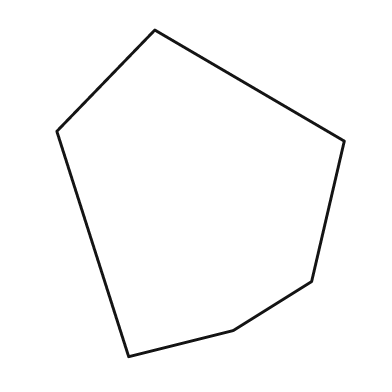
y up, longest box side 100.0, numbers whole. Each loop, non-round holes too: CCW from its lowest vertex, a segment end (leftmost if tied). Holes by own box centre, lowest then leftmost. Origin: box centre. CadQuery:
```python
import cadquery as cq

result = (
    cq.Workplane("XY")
    .moveTo(-22.0, -50.0)
    .lineTo(10.0, -42.0)
    .lineTo(34.0, -27.0)
    .lineTo(44.0, 16.0)
    .lineTo(-14.0, 50.0)
    .lineTo(-44.0, 19.0)
    .close()
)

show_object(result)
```